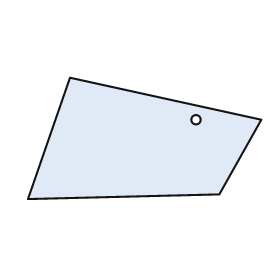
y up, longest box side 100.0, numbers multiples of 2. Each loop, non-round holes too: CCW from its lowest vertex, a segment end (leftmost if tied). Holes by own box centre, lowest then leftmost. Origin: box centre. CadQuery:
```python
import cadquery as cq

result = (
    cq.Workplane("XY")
    .moveTo(-50.0, -26.0)
    .lineTo(32.0, -24.0)
    .lineTo(50.0, 8.0)
    .lineTo(-32.0, 26.0)
    .close()
    .moveTo(22.0, 8.0)
    .circle(2.0)
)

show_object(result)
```